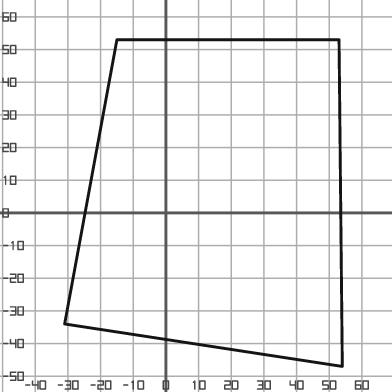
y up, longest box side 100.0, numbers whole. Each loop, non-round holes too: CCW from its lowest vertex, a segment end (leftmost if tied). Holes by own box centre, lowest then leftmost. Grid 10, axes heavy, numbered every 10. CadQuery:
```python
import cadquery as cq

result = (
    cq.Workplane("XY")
    .moveTo(54.0, -47.0)
    .lineTo(53.0, 53.0)
    .lineTo(-15.0, 53.0)
    .lineTo(-31.0, -34.0)
    .close()
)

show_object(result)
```